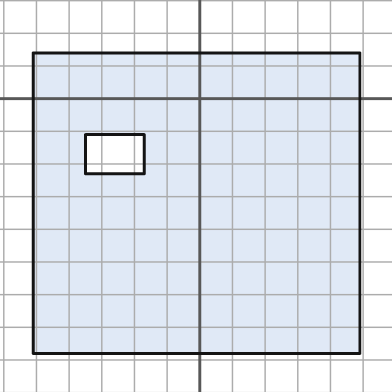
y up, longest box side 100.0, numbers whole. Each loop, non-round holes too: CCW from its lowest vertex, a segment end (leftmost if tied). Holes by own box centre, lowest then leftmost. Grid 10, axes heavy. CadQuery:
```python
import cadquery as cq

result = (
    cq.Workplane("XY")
    .moveTo(-51.0, -78.0)
    .lineTo(49.0, -78.0)
    .lineTo(49.0, 14.0)
    .lineTo(-51.0, 14.0)
    .close()
    .moveTo(-35.0, -23.0)
    .lineTo(-17.0, -23.0)
    .lineTo(-17.0, -11.0)
    .lineTo(-35.0, -11.0)
    .close()
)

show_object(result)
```